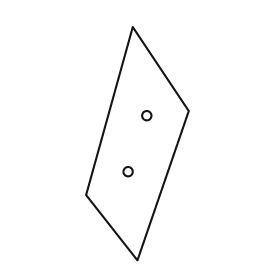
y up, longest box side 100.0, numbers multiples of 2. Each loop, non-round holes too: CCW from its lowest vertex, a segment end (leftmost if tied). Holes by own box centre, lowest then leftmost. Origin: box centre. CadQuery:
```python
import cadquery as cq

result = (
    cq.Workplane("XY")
    .moveTo(0.0, -50.0)
    .lineTo(22.0, 14.0)
    .lineTo(-2.0, 50.0)
    .lineTo(-22.0, -22.0)
    .close()
    .moveTo(-4.0, -12.0)
    .circle(2.0)
    .moveTo(4.0, 12.0)
    .circle(2.0)
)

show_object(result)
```